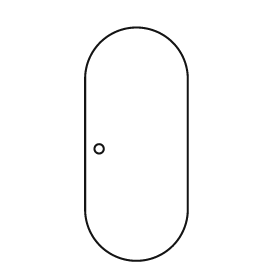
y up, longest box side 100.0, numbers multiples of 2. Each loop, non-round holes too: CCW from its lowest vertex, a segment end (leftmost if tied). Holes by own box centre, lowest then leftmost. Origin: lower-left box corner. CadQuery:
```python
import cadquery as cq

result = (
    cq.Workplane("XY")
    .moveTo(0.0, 22.0)
    .threePointArc((22.0, 0.0), (44.0, 22.0))
    .lineTo(44.0, 78.0)
    .threePointArc((22.0, 100.0), (0.0, 78.0))
    .close()
    .moveTo(6.0, 48.0)
    .circle(2.0)
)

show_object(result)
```